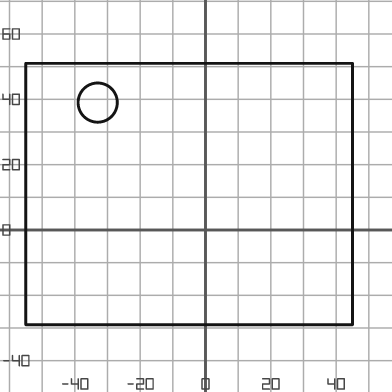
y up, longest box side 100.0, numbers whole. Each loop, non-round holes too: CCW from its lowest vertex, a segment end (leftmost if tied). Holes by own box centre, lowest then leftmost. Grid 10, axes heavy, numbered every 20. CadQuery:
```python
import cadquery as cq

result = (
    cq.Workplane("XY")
    .moveTo(-55.0, -29.0)
    .lineTo(45.0, -29.0)
    .lineTo(45.0, 51.0)
    .lineTo(-55.0, 51.0)
    .close()
    .moveTo(-33.0, 39.0)
    .circle(6.0)
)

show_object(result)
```